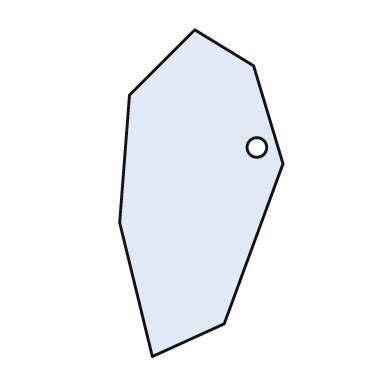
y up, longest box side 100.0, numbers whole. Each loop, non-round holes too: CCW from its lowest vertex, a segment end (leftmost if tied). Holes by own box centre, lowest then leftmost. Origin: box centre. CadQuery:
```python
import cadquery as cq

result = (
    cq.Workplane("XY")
    .moveTo(-15.0, -50.0)
    .lineTo(7.0, -40.0)
    .lineTo(25.0, 9.0)
    .lineTo(16.0, 39.0)
    .lineTo(-2.0, 50.0)
    .lineTo(-22.0, 30.0)
    .lineTo(-25.0, -9.0)
    .close()
    .moveTo(17.0, 14.0)
    .circle(3.0)
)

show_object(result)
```